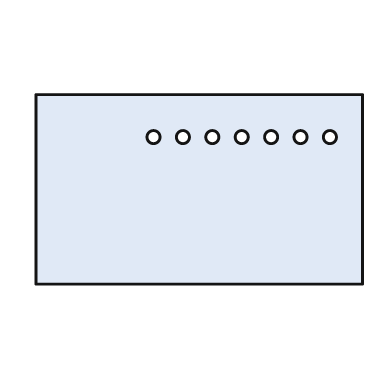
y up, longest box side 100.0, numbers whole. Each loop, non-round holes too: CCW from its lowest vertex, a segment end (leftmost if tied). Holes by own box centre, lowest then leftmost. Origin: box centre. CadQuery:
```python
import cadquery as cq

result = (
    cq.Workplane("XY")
    .moveTo(-50.0, -29.0)
    .lineTo(50.0, -29.0)
    .lineTo(50.0, 29.0)
    .lineTo(-50.0, 29.0)
    .close()
    .moveTo(-14.0, 16.0)
    .circle(2.0)
    .moveTo(-5.0, 16.0)
    .circle(2.0)
    .moveTo(4.0, 16.0)
    .circle(2.0)
    .moveTo(13.0, 16.0)
    .circle(2.0)
    .moveTo(22.0, 16.0)
    .circle(2.0)
    .moveTo(31.0, 16.0)
    .circle(2.0)
    .moveTo(40.0, 16.0)
    .circle(2.0)
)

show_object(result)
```